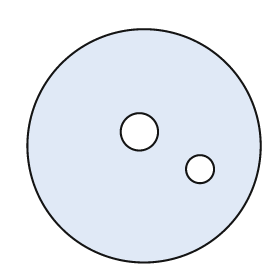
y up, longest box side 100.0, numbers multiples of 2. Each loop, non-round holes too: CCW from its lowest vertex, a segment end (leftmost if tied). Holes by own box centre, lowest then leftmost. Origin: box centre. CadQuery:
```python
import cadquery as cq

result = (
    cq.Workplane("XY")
    .moveTo(0.0, 0.0)
    .circle(50.0)
    .moveTo(24.0, -10.0)
    .circle(6.0)
    .moveTo(-2.0, 6.0)
    .circle(8.0)
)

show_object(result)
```